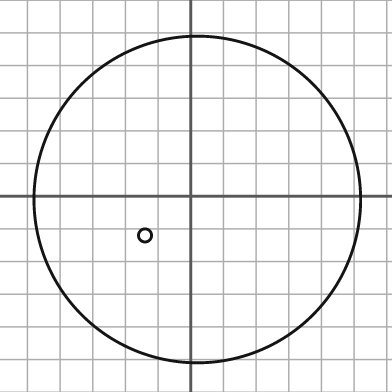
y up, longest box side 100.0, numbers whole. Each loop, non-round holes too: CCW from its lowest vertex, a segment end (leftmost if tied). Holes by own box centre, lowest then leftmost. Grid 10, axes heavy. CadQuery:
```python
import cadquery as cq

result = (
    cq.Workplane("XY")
    .moveTo(2.0, -1.0)
    .circle(50.0)
    .moveTo(-14.0, -12.0)
    .circle(2.0)
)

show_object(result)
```